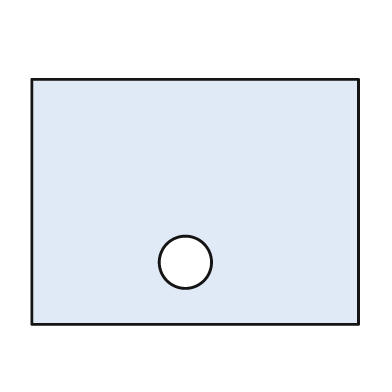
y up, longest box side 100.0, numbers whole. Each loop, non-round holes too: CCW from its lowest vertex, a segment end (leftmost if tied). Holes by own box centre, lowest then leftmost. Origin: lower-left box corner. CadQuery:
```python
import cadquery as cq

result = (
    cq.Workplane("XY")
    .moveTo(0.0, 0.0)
    .lineTo(100.0, 0.0)
    .lineTo(100.0, 75.0)
    .lineTo(0.0, 75.0)
    .close()
    .moveTo(47.0, 19.0)
    .circle(8.0)
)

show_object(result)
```